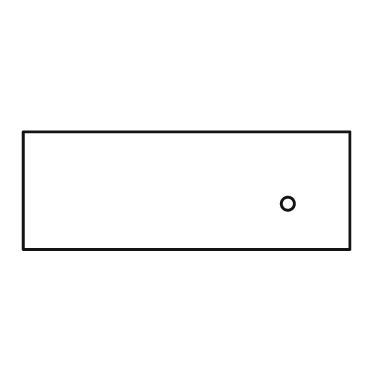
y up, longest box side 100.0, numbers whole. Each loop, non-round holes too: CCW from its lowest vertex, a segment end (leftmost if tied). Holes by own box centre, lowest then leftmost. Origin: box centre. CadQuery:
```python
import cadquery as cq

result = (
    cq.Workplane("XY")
    .moveTo(-50.0, -18.0)
    .lineTo(50.0, -18.0)
    .lineTo(50.0, 18.0)
    .lineTo(-50.0, 18.0)
    .close()
    .moveTo(31.0, -4.0)
    .circle(2.0)
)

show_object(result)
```